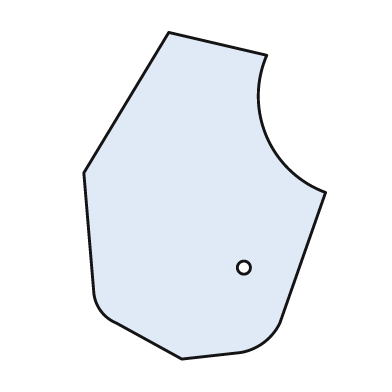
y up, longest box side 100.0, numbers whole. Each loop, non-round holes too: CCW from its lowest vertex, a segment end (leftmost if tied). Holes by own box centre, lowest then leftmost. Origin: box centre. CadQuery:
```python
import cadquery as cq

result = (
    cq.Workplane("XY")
    .moveTo(-7.0, -50.0)
    .lineTo(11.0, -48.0)
    .threePointArc((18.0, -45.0), (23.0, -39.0))
    .lineTo(37.0, 1.0)
    .threePointArc((19.0, 18.0), (19.0, 43.0))
    .lineTo(-11.0, 50.0)
    .lineTo(-37.0, 7.0)
    .lineTo(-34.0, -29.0)
    .threePointArc((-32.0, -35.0), (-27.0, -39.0))
    .close()
    .moveTo(12.0, -22.0)
    .circle(2.0)
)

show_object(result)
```